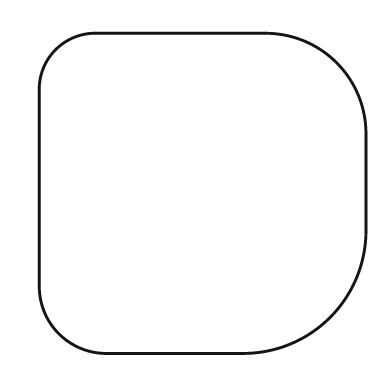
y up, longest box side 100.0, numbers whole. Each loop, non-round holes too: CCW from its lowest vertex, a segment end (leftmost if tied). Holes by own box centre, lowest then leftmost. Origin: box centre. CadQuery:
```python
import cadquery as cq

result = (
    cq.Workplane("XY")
    .moveTo(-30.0, -49.0)
    .lineTo(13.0, -49.0)
    .threePointArc((39.0, -38.0), (50.0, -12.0))
    .lineTo(50.0, 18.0)
    .threePointArc((41.0, 40.0), (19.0, 49.0))
    .lineTo(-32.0, 49.0)
    .threePointArc((-45.0, 44.0), (-50.0, 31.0))
    .lineTo(-50.0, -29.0)
    .threePointArc((-44.0, -43.0), (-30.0, -49.0))
    .close()
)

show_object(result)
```